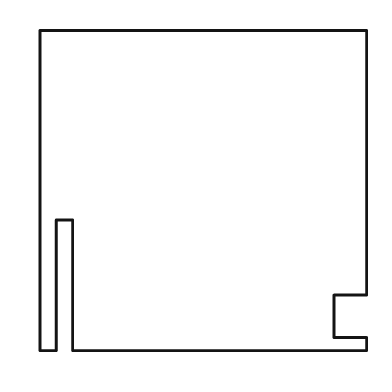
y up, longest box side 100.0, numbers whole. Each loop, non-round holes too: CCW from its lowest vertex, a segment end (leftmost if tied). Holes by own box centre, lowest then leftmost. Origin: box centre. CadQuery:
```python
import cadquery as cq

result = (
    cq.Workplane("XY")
    .moveTo(-50.0, -49.0)
    .lineTo(-45.0, -49.0)
    .lineTo(-45.0, -9.0)
    .lineTo(-40.0, -9.0)
    .lineTo(-40.0, -49.0)
    .lineTo(50.0, -49.0)
    .lineTo(50.0, -45.0)
    .lineTo(40.0, -45.0)
    .lineTo(40.0, -32.0)
    .lineTo(50.0, -32.0)
    .lineTo(50.0, 49.0)
    .lineTo(-50.0, 49.0)
    .close()
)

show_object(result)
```